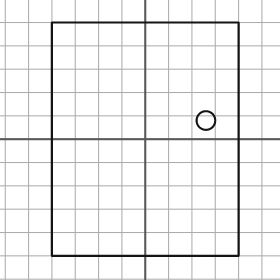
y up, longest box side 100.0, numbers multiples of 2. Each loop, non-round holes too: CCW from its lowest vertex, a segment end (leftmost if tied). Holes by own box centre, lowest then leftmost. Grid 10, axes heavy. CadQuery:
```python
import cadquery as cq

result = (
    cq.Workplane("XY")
    .moveTo(-40.0, -50.0)
    .lineTo(40.0, -50.0)
    .lineTo(40.0, 50.0)
    .lineTo(-40.0, 50.0)
    .close()
    .moveTo(26.0, 8.0)
    .circle(4.0)
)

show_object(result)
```